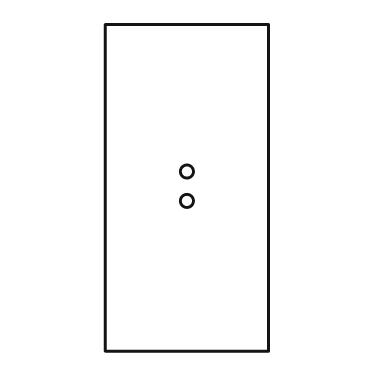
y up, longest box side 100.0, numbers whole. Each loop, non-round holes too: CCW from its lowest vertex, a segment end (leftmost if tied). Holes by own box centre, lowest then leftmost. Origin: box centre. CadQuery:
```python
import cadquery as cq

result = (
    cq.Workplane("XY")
    .moveTo(-25.0, -50.0)
    .lineTo(25.0, -50.0)
    .lineTo(25.0, 50.0)
    .lineTo(-25.0, 50.0)
    .close()
    .moveTo(0.0, -4.0)
    .circle(2.0)
    .moveTo(0.0, 5.0)
    .circle(2.0)
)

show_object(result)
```